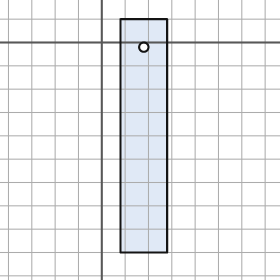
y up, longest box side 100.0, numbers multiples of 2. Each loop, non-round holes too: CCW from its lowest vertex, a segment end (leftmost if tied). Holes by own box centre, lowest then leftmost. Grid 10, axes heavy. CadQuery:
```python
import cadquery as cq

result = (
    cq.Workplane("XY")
    .moveTo(8.0, -90.0)
    .lineTo(28.0, -90.0)
    .lineTo(28.0, 10.0)
    .lineTo(8.0, 10.0)
    .close()
    .moveTo(18.0, -2.0)
    .circle(2.0)
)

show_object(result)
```